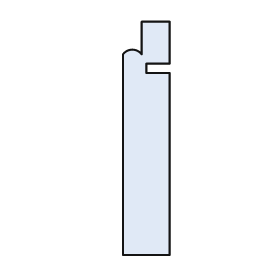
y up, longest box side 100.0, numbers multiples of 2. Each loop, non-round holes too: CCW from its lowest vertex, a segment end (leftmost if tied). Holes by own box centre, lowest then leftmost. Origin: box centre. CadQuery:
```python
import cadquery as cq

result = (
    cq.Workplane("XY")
    .moveTo(-10.0, -50.0)
    .lineTo(10.0, -50.0)
    .lineTo(10.0, 28.0)
    .lineTo(0.0, 28.0)
    .lineTo(0.0, 32.0)
    .lineTo(10.0, 32.0)
    .lineTo(10.0, 50.0)
    .lineTo(-2.0, 50.0)
    .lineTo(-2.0, 36.0)
    .threePointArc((-6.0, 38.0), (-10.0, 36.0))
    .close()
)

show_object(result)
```